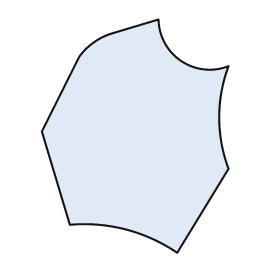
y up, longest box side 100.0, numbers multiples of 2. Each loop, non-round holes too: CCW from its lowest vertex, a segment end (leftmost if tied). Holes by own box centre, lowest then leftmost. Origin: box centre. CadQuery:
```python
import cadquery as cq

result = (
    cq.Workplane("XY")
    .moveTo(18.0, -50.0)
    .lineTo(40.0, -14.0)
    .threePointArc((36.0, 8.0), (40.0, 30.0))
    .threePointArc((20.0, 32.0), (10.0, 50.0))
    .lineTo(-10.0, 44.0)
    .threePointArc((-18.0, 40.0), (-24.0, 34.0))
    .lineTo(-40.0, 2.0)
    .lineTo(-28.0, -38.0)
    .threePointArc((-4.0, -40.0), (18.0, -50.0))
    .close()
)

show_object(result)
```